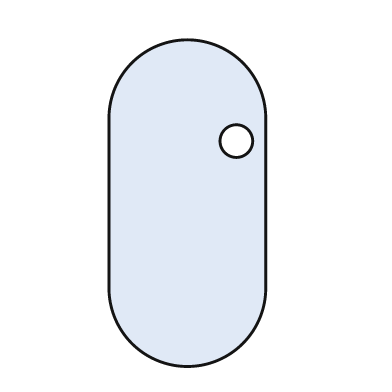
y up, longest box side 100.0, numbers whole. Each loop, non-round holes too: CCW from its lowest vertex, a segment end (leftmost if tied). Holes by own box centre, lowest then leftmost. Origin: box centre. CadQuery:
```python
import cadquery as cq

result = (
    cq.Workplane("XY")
    .moveTo(-24.0, -26.0)
    .threePointArc((0.0, -50.0), (24.0, -26.0))
    .lineTo(24.0, 26.0)
    .threePointArc((0.0, 50.0), (-24.0, 26.0))
    .close()
    .moveTo(15.0, 19.0)
    .circle(5.0)
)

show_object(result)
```